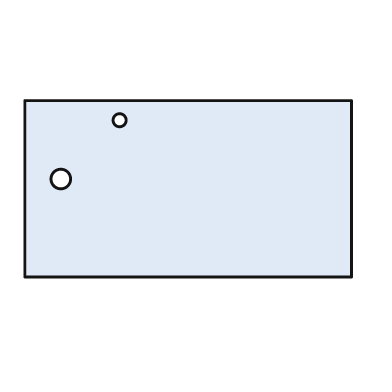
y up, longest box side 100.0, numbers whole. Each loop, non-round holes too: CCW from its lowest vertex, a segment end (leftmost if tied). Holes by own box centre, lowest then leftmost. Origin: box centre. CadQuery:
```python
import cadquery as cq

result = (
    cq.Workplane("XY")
    .moveTo(-50.0, -27.0)
    .lineTo(50.0, -27.0)
    .lineTo(50.0, 27.0)
    .lineTo(-50.0, 27.0)
    .close()
    .moveTo(-39.0, 3.0)
    .circle(3.0)
    .moveTo(-21.0, 21.0)
    .circle(2.0)
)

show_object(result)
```